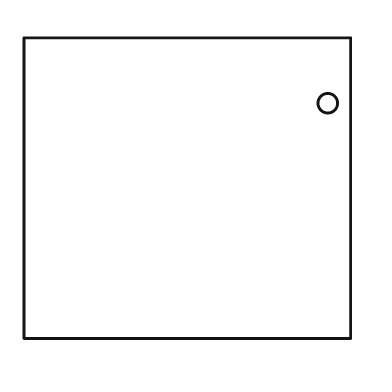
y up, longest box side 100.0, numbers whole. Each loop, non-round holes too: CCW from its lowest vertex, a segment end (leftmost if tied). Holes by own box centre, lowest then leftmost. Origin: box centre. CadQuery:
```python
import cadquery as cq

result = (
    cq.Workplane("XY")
    .moveTo(-50.0, -46.0)
    .lineTo(50.0, -46.0)
    .lineTo(50.0, 46.0)
    .lineTo(-50.0, 46.0)
    .close()
    .moveTo(43.0, 26.0)
    .circle(3.0)
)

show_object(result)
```